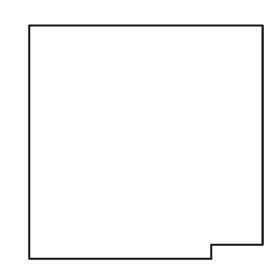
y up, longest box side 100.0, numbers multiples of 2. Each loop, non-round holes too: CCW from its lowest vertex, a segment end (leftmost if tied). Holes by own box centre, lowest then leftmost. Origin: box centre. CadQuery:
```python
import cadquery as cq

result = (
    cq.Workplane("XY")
    .moveTo(-50.0, -50.0)
    .lineTo(28.0, -50.0)
    .lineTo(28.0, -44.0)
    .lineTo(50.0, -44.0)
    .lineTo(50.0, 50.0)
    .lineTo(-50.0, 50.0)
    .close()
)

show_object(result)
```